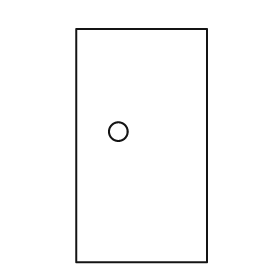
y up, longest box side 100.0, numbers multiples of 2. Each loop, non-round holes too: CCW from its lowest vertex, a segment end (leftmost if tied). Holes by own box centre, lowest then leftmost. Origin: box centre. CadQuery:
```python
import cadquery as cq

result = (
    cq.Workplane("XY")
    .moveTo(-28.0, -50.0)
    .lineTo(28.0, -50.0)
    .lineTo(28.0, 50.0)
    .lineTo(-28.0, 50.0)
    .close()
    .moveTo(-10.0, 6.0)
    .circle(4.0)
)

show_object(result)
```